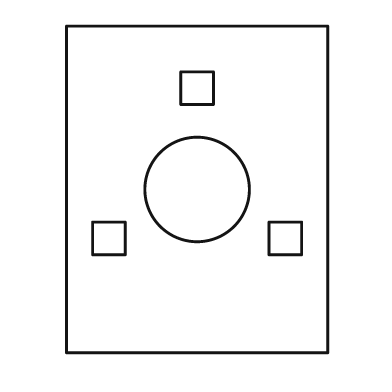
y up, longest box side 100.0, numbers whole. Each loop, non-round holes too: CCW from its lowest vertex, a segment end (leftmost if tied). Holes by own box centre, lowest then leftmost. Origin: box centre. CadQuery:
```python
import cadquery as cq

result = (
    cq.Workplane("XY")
    .moveTo(-40.0, -50.0)
    .lineTo(40.0, -50.0)
    .lineTo(40.0, 50.0)
    .lineTo(-40.0, 50.0)
    .close()
    .moveTo(-32.0, -20.0)
    .lineTo(-22.0, -20.0)
    .lineTo(-22.0, -10.0)
    .lineTo(-32.0, -10.0)
    .close()
    .moveTo(22.0, -20.0)
    .lineTo(32.0, -20.0)
    .lineTo(32.0, -10.0)
    .lineTo(22.0, -10.0)
    .close()
    .moveTo(0.0, 0.0)
    .circle(16.0)
    .moveTo(-5.0, 26.0)
    .lineTo(5.0, 26.0)
    .lineTo(5.0, 36.0)
    .lineTo(-5.0, 36.0)
    .close()
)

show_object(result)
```